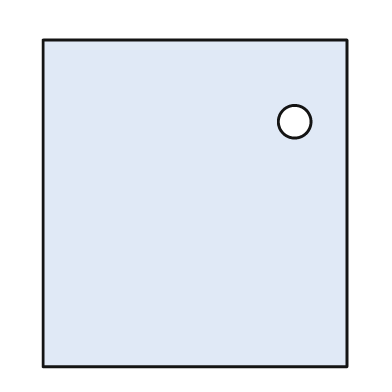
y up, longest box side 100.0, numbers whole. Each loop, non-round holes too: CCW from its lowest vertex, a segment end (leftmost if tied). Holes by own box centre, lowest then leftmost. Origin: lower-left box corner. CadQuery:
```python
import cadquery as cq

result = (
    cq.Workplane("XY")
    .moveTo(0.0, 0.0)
    .lineTo(93.0, 0.0)
    .lineTo(93.0, 100.0)
    .lineTo(0.0, 100.0)
    .close()
    .moveTo(77.0, 75.0)
    .circle(5.0)
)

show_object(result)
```